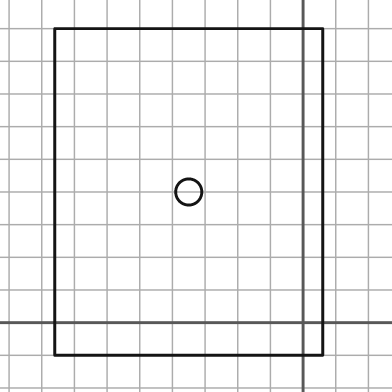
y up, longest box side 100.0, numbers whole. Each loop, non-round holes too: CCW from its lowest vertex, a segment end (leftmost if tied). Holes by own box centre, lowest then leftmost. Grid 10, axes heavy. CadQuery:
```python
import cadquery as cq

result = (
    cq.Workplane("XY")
    .moveTo(-76.0, -10.0)
    .lineTo(6.0, -10.0)
    .lineTo(6.0, 90.0)
    .lineTo(-76.0, 90.0)
    .close()
    .moveTo(-35.0, 40.0)
    .circle(4.0)
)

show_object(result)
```